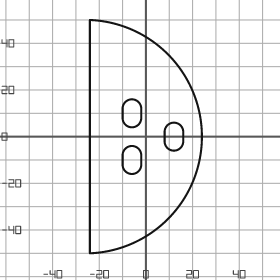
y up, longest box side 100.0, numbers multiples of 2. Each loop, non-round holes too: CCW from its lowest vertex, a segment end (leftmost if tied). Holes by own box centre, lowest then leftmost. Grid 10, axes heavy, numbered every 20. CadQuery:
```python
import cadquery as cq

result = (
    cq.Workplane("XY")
    .moveTo(-24.0, -50.0)
    .threePointArc((24.0, 0.0), (-24.0, 50.0))
    .close()
    .moveTo(-10.0, -12.0)
    .threePointArc((-6.0, -16.0), (-2.0, -12.0))
    .lineTo(-2.0, -8.0)
    .threePointArc((-6.0, -4.0), (-10.0, -8.0))
    .close()
    .moveTo(8.0, -2.0)
    .threePointArc((12.0, -6.0), (16.0, -2.0))
    .lineTo(16.0, 2.0)
    .threePointArc((12.0, 6.0), (8.0, 2.0))
    .close()
    .moveTo(-10.0, 8.0)
    .threePointArc((-6.0, 4.0), (-2.0, 8.0))
    .lineTo(-2.0, 12.0)
    .threePointArc((-6.0, 16.0), (-10.0, 12.0))
    .close()
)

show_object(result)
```